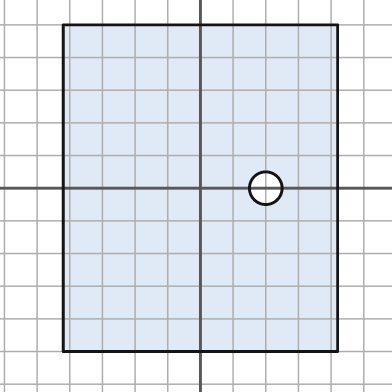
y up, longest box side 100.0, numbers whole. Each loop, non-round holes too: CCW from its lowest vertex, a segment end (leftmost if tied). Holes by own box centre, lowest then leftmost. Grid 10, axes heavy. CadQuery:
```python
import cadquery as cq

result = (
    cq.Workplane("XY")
    .moveTo(-42.0, -50.0)
    .lineTo(42.0, -50.0)
    .lineTo(42.0, 50.0)
    .lineTo(-42.0, 50.0)
    .close()
    .moveTo(20.0, 0.0)
    .circle(5.0)
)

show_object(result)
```